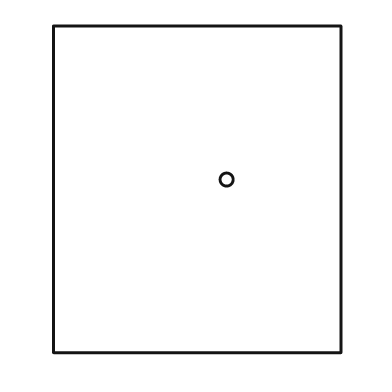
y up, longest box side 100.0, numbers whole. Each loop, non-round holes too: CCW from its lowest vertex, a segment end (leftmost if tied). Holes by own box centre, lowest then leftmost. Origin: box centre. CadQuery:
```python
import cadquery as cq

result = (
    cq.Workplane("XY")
    .moveTo(-44.0, -50.0)
    .lineTo(44.0, -50.0)
    .lineTo(44.0, 50.0)
    .lineTo(-44.0, 50.0)
    .close()
    .moveTo(9.0, 3.0)
    .circle(2.0)
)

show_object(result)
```